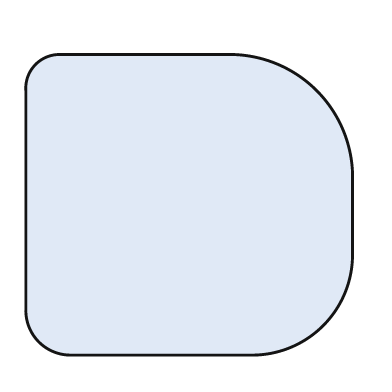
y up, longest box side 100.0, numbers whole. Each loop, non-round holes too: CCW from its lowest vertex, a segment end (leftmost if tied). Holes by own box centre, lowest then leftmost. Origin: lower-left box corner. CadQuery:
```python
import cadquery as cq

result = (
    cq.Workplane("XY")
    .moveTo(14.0, 0.0)
    .lineTo(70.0, 0.0)
    .threePointArc((91.0, 9.0), (100.0, 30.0))
    .lineTo(100.0, 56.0)
    .threePointArc((89.0, 81.0), (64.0, 92.0))
    .lineTo(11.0, 92.0)
    .threePointArc((3.0, 89.0), (0.0, 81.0))
    .lineTo(0.0, 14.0)
    .threePointArc((4.0, 4.0), (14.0, 0.0))
    .close()
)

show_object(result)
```